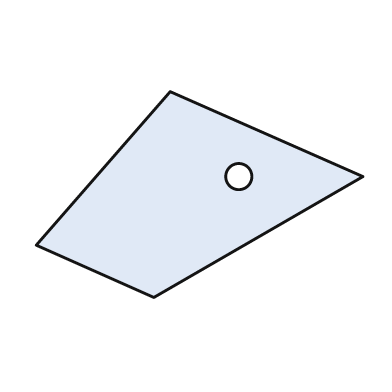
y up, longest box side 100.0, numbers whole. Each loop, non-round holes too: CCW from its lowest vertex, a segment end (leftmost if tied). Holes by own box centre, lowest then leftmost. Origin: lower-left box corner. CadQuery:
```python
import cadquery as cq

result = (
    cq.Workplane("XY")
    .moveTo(36.0, 0.0)
    .lineTo(100.0, 37.0)
    .lineTo(41.0, 63.0)
    .lineTo(0.0, 16.0)
    .close()
    .moveTo(62.0, 37.0)
    .circle(4.0)
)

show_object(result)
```